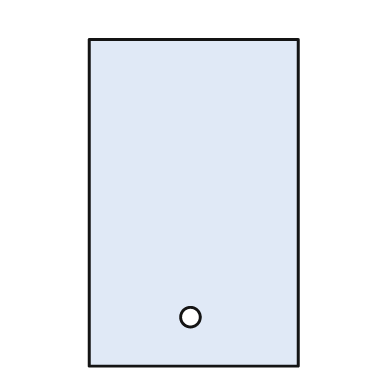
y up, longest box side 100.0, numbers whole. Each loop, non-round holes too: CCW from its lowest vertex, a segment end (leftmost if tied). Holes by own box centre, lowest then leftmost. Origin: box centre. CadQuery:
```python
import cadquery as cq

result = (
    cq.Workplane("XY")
    .moveTo(-32.0, -50.0)
    .lineTo(32.0, -50.0)
    .lineTo(32.0, 50.0)
    .lineTo(-32.0, 50.0)
    .close()
    .moveTo(-1.0, -35.0)
    .circle(3.0)
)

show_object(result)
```